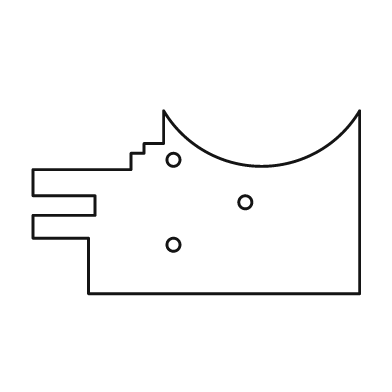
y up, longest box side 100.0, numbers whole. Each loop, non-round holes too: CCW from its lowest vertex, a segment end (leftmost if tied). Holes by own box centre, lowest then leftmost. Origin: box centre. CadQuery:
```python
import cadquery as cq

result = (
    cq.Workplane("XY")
    .moveTo(-33.0, -28.0)
    .lineTo(50.0, -28.0)
    .lineTo(50.0, 28.0)
    .threePointArc((20.0, 11.0), (-10.0, 28.0))
    .lineTo(-10.0, 18.0)
    .lineTo(-16.0, 18.0)
    .lineTo(-16.0, 15.0)
    .lineTo(-20.0, 15.0)
    .lineTo(-20.0, 10.0)
    .lineTo(-50.0, 10.0)
    .lineTo(-50.0, 2.0)
    .lineTo(-31.0, 2.0)
    .lineTo(-31.0, -4.0)
    .lineTo(-50.0, -4.0)
    .lineTo(-50.0, -11.0)
    .lineTo(-33.0, -11.0)
    .close()
    .moveTo(-7.0, -13.0)
    .circle(2.0)
    .moveTo(15.0, 0.0)
    .circle(2.0)
    .moveTo(-7.0, 13.0)
    .circle(2.0)
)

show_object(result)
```